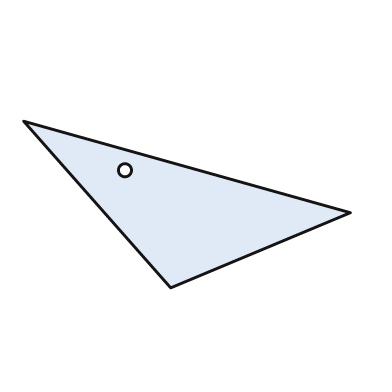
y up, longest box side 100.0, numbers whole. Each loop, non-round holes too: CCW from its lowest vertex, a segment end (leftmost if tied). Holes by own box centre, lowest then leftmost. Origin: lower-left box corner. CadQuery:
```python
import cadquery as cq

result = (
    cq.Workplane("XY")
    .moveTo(45.0, 0.0)
    .lineTo(100.0, 23.0)
    .lineTo(0.0, 51.0)
    .close()
    .moveTo(31.0, 36.0)
    .circle(2.0)
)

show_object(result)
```